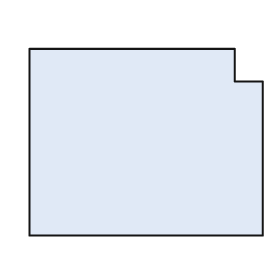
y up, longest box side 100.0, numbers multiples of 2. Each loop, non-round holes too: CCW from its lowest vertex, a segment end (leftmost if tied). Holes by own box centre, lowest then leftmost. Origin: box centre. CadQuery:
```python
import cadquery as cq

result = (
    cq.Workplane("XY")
    .moveTo(-50.0, -40.0)
    .lineTo(50.0, -40.0)
    .lineTo(50.0, 26.0)
    .lineTo(38.0, 26.0)
    .lineTo(38.0, 40.0)
    .lineTo(-50.0, 40.0)
    .close()
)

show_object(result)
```